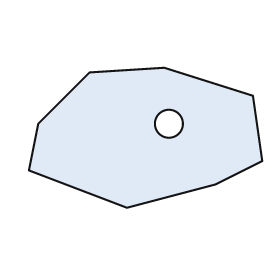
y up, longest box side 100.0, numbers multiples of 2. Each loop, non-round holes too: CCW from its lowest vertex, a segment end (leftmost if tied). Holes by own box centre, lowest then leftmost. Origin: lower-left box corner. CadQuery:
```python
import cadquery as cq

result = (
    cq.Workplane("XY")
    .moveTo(42.0, 0.0)
    .lineTo(80.0, 10.0)
    .lineTo(100.0, 20.0)
    .lineTo(96.0, 48.0)
    .lineTo(58.0, 60.0)
    .lineTo(26.0, 58.0)
    .lineTo(4.0, 36.0)
    .lineTo(0.0, 16.0)
    .close()
    .moveTo(60.0, 36.0)
    .circle(6.0)
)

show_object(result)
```